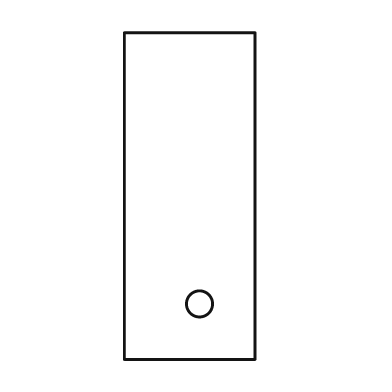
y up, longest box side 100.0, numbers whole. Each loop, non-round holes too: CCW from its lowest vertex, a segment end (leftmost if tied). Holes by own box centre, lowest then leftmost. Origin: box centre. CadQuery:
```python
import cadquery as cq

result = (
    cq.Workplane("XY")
    .moveTo(-20.0, -50.0)
    .lineTo(20.0, -50.0)
    .lineTo(20.0, 50.0)
    .lineTo(-20.0, 50.0)
    .close()
    .moveTo(3.0, -33.0)
    .circle(4.0)
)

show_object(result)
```